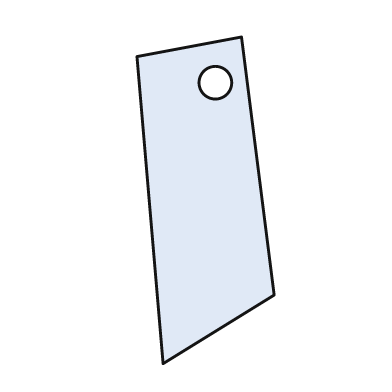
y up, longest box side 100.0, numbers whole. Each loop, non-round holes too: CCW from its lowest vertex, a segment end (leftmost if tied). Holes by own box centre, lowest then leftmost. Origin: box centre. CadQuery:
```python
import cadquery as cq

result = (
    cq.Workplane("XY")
    .moveTo(-13.0, -50.0)
    .lineTo(21.0, -29.0)
    .lineTo(11.0, 50.0)
    .lineTo(-21.0, 44.0)
    .close()
    .moveTo(3.0, 36.0)
    .circle(5.0)
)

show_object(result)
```